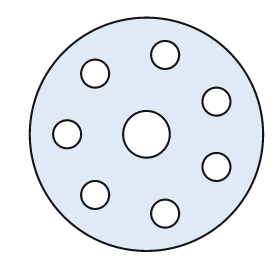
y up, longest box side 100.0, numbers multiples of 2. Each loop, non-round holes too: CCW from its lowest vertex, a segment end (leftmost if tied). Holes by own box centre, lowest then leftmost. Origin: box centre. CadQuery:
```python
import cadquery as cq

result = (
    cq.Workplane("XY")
    .moveTo(0.0, 0.0)
    .circle(50.0)
    .moveTo(8.0, -34.0)
    .circle(6.0)
    .moveTo(-22.0, -26.0)
    .circle(6.0)
    .moveTo(30.0, -14.0)
    .circle(6.0)
    .moveTo(-34.0, 0.0)
    .circle(6.0)
    .moveTo(0.0, 0.0)
    .circle(10.0)
    .moveTo(30.0, 14.0)
    .circle(6.0)
    .moveTo(-22.0, 26.0)
    .circle(6.0)
    .moveTo(8.0, 34.0)
    .circle(6.0)
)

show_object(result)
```